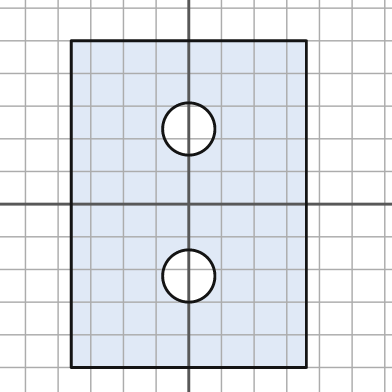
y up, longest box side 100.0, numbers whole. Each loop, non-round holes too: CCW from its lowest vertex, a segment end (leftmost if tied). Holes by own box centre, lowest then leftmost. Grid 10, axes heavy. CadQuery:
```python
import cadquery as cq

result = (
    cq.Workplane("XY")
    .moveTo(-36.0, -50.0)
    .lineTo(36.0, -50.0)
    .lineTo(36.0, 50.0)
    .lineTo(-36.0, 50.0)
    .close()
    .moveTo(0.0, -22.0)
    .circle(8.0)
    .moveTo(0.0, 23.0)
    .circle(8.0)
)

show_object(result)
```